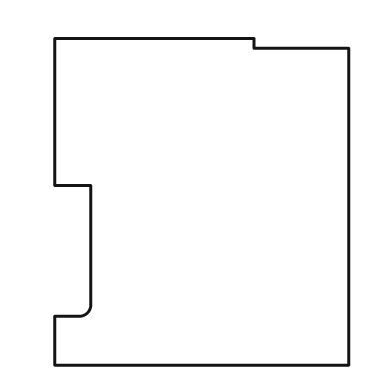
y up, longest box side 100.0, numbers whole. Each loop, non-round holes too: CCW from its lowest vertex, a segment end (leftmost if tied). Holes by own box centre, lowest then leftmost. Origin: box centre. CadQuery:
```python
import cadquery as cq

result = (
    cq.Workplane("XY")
    .moveTo(-45.0, -50.0)
    .lineTo(45.0, -50.0)
    .lineTo(45.0, 47.0)
    .lineTo(16.0, 47.0)
    .lineTo(16.0, 50.0)
    .lineTo(-45.0, 50.0)
    .lineTo(-45.0, 5.0)
    .lineTo(-34.0, 5.0)
    .lineTo(-34.0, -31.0)
    .threePointArc((-35.0, -34.0), (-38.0, -35.0))
    .lineTo(-45.0, -35.0)
    .close()
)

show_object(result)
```